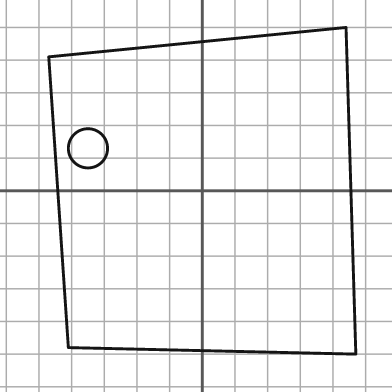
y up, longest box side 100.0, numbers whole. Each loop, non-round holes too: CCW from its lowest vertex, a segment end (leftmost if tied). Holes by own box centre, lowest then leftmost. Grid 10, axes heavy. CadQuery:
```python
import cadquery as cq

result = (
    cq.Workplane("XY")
    .moveTo(47.0, -50.0)
    .lineTo(44.0, 50.0)
    .lineTo(-47.0, 41.0)
    .lineTo(-41.0, -48.0)
    .close()
    .moveTo(-35.0, 13.0)
    .circle(6.0)
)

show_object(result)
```